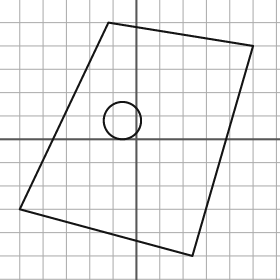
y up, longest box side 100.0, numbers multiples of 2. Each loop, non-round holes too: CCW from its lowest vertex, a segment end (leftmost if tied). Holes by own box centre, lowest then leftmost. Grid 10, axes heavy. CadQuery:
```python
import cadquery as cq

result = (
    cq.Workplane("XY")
    .moveTo(24.0, -50.0)
    .lineTo(50.0, 40.0)
    .lineTo(-12.0, 50.0)
    .lineTo(-50.0, -30.0)
    .close()
    .moveTo(-6.0, 8.0)
    .circle(8.0)
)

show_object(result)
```